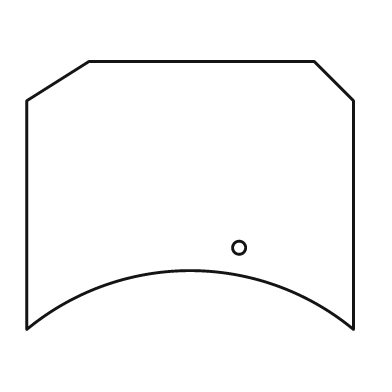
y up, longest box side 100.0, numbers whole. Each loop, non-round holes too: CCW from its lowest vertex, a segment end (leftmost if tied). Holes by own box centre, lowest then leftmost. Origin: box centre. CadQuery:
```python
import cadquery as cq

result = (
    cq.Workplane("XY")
    .moveTo(-50.0, -41.0)
    .threePointArc((0.0, -23.0), (50.0, -41.0))
    .lineTo(50.0, 29.0)
    .lineTo(38.0, 41.0)
    .lineTo(-31.0, 41.0)
    .lineTo(-50.0, 29.0)
    .close()
    .moveTo(15.0, -16.0)
    .circle(2.0)
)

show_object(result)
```